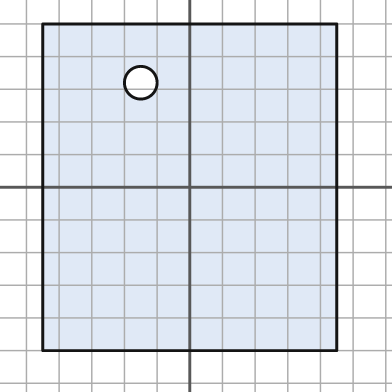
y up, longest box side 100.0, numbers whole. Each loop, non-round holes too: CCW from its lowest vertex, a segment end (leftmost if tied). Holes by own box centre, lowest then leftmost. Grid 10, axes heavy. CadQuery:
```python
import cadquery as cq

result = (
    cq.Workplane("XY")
    .moveTo(-45.0, -50.0)
    .lineTo(45.0, -50.0)
    .lineTo(45.0, 50.0)
    .lineTo(-45.0, 50.0)
    .close()
    .moveTo(-15.0, 32.0)
    .circle(5.0)
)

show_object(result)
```